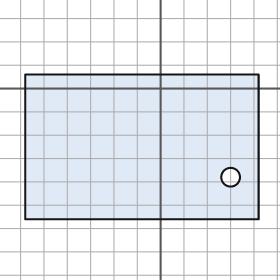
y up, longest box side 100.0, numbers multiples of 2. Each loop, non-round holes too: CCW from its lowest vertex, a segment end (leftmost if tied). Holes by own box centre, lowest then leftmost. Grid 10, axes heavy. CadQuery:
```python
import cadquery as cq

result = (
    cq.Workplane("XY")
    .moveTo(-58.0, -56.0)
    .lineTo(42.0, -56.0)
    .lineTo(42.0, 6.0)
    .lineTo(-58.0, 6.0)
    .close()
    .moveTo(30.0, -38.0)
    .circle(4.0)
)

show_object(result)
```